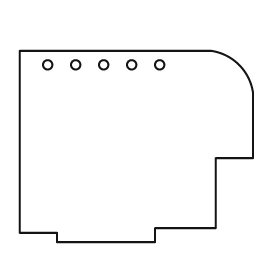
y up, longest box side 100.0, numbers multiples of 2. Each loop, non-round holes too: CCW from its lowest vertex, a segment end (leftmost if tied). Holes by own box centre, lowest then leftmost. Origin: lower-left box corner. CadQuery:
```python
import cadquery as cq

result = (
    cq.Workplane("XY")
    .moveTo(16.0, 0.0)
    .lineTo(58.0, 0.0)
    .lineTo(58.0, 6.0)
    .lineTo(84.0, 6.0)
    .lineTo(84.0, 36.0)
    .lineTo(100.0, 36.0)
    .lineTo(100.0, 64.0)
    .threePointArc((94.0, 76.0), (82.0, 82.0))
    .lineTo(0.0, 82.0)
    .lineTo(0.0, 4.0)
    .lineTo(16.0, 4.0)
    .close()
    .moveTo(12.0, 76.0)
    .circle(2.0)
    .moveTo(24.0, 76.0)
    .circle(2.0)
    .moveTo(36.0, 76.0)
    .circle(2.0)
    .moveTo(48.0, 76.0)
    .circle(2.0)
    .moveTo(60.0, 76.0)
    .circle(2.0)
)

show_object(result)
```